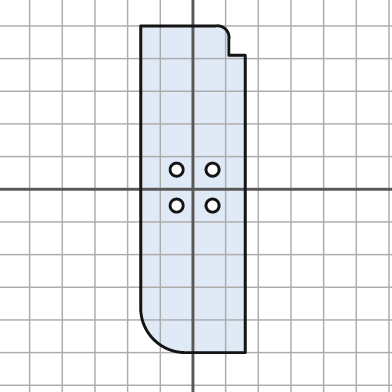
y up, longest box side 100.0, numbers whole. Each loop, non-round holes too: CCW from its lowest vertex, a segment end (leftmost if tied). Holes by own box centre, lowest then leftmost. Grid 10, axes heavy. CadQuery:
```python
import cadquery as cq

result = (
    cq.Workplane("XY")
    .moveTo(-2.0, -50.0)
    .lineTo(16.0, -50.0)
    .lineTo(16.0, 41.0)
    .lineTo(11.0, 41.0)
    .lineTo(11.0, 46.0)
    .threePointArc((10.0, 49.0), (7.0, 50.0))
    .lineTo(-16.0, 50.0)
    .lineTo(-16.0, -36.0)
    .threePointArc((-12.0, -46.0), (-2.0, -50.0))
    .close()
    .moveTo(-5.0, -5.0)
    .circle(2.0)
    .moveTo(6.0, -5.0)
    .circle(2.0)
    .moveTo(-5.0, 6.0)
    .circle(2.0)
    .moveTo(6.0, 6.0)
    .circle(2.0)
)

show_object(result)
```